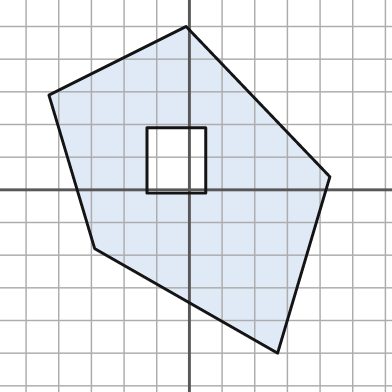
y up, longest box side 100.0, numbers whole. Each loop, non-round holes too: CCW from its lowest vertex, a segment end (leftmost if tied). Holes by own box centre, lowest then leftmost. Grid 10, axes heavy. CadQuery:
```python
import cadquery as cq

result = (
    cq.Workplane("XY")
    .moveTo(27.0, -50.0)
    .lineTo(43.0, 4.0)
    .lineTo(-1.0, 50.0)
    .lineTo(-43.0, 29.0)
    .lineTo(-29.0, -18.0)
    .close()
    .moveTo(-13.0, -1.0)
    .lineTo(5.0, -1.0)
    .lineTo(5.0, 19.0)
    .lineTo(-13.0, 19.0)
    .close()
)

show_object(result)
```